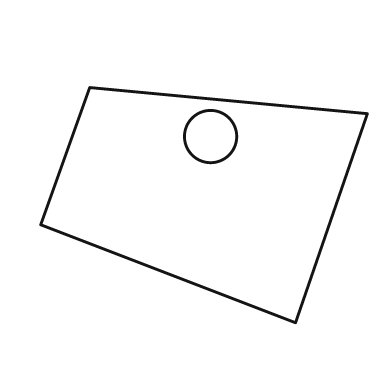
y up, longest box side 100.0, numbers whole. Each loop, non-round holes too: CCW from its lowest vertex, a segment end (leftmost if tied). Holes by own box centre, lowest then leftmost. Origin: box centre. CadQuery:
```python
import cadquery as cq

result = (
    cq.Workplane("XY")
    .moveTo(28.0, -36.0)
    .lineTo(50.0, 28.0)
    .lineTo(-35.0, 36.0)
    .lineTo(-50.0, -6.0)
    .close()
    .moveTo(2.0, 21.0)
    .circle(8.0)
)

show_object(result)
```